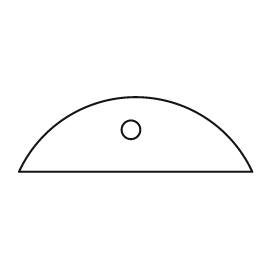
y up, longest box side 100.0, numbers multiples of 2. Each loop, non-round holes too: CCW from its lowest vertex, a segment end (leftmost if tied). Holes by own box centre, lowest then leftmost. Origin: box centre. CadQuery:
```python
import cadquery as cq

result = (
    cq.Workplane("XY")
    .moveTo(-50.0, -16.0)
    .lineTo(50.0, -16.0)
    .threePointArc((0.0, 16.0), (-50.0, -16.0))
    .close()
    .moveTo(-2.0, 2.0)
    .circle(4.0)
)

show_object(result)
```